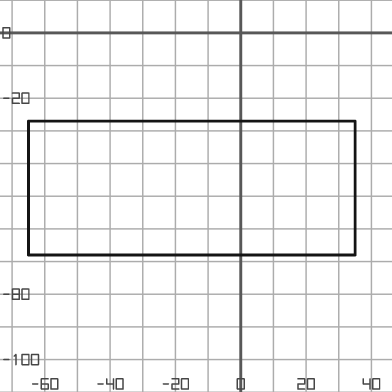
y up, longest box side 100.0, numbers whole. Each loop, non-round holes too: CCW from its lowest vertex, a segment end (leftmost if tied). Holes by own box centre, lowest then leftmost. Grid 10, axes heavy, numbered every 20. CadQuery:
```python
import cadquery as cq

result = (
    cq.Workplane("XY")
    .moveTo(-65.0, -68.0)
    .lineTo(35.0, -68.0)
    .lineTo(35.0, -27.0)
    .lineTo(-65.0, -27.0)
    .close()
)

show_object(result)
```